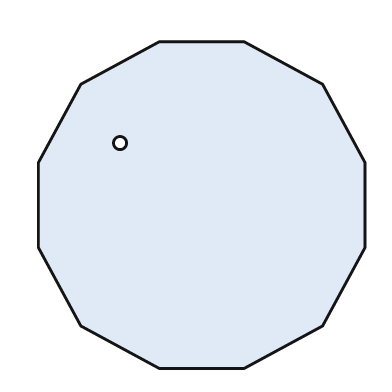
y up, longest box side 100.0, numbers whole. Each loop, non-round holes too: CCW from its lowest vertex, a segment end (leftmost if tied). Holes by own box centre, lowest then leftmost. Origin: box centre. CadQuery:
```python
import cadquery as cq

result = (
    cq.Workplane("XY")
    .moveTo(-13.0, -50.0)
    .lineTo(13.0, -50.0)
    .lineTo(37.0, -37.0)
    .lineTo(50.0, -13.0)
    .lineTo(50.0, 13.0)
    .lineTo(37.0, 37.0)
    .lineTo(13.0, 50.0)
    .lineTo(-13.0, 50.0)
    .lineTo(-37.0, 37.0)
    .lineTo(-50.0, 13.0)
    .lineTo(-50.0, -13.0)
    .lineTo(-37.0, -37.0)
    .close()
    .moveTo(-25.0, 19.0)
    .circle(2.0)
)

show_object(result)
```